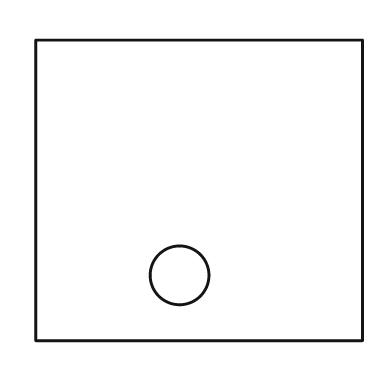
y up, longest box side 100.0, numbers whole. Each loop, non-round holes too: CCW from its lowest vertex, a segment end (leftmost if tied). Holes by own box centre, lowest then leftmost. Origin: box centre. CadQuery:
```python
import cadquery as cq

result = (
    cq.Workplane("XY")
    .moveTo(-50.0, -46.0)
    .lineTo(50.0, -46.0)
    .lineTo(50.0, 46.0)
    .lineTo(-50.0, 46.0)
    .close()
    .moveTo(-6.0, -26.0)
    .circle(9.0)
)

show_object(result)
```